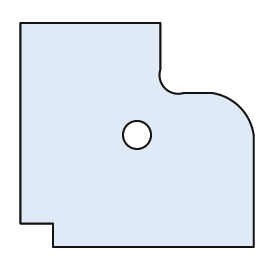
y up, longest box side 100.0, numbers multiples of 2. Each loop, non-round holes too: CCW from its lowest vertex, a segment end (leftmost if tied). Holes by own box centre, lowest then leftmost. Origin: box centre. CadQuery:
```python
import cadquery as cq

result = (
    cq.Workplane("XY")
    .moveTo(-36.0, -48.0)
    .lineTo(50.0, -48.0)
    .lineTo(50.0, 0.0)
    .threePointArc((44.0, 12.0), (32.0, 18.0))
    .lineTo(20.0, 18.0)
    .threePointArc((12.0, 20.0), (10.0, 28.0))
    .lineTo(10.0, 48.0)
    .lineTo(-50.0, 48.0)
    .lineTo(-50.0, -38.0)
    .lineTo(-36.0, -38.0)
    .close()
    .moveTo(0.0, 0.0)
    .circle(6.0)
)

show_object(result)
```